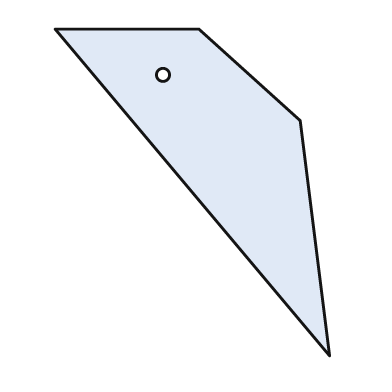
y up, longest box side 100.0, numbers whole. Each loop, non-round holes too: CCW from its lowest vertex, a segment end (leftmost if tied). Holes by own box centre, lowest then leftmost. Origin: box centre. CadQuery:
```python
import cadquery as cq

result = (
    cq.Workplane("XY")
    .moveTo(42.0, -50.0)
    .lineTo(33.0, 22.0)
    .lineTo(2.0, 50.0)
    .lineTo(-42.0, 50.0)
    .close()
    .moveTo(-9.0, 36.0)
    .circle(2.0)
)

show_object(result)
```